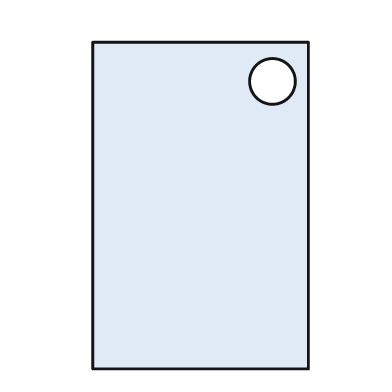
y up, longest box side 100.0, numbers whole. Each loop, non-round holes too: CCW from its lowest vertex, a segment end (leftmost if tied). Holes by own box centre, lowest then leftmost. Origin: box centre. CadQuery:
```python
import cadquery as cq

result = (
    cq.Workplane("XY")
    .moveTo(-33.0, -50.0)
    .lineTo(33.0, -50.0)
    .lineTo(33.0, 50.0)
    .lineTo(-33.0, 50.0)
    .close()
    .moveTo(22.0, 38.0)
    .circle(7.0)
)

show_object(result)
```